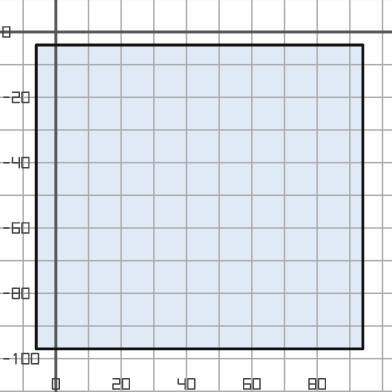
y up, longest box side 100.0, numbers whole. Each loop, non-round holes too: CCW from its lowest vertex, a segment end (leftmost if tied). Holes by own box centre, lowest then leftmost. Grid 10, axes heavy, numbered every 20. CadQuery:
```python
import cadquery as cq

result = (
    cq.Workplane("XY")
    .moveTo(-6.0, -97.0)
    .lineTo(94.0, -97.0)
    .lineTo(94.0, -4.0)
    .lineTo(-6.0, -4.0)
    .close()
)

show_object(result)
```